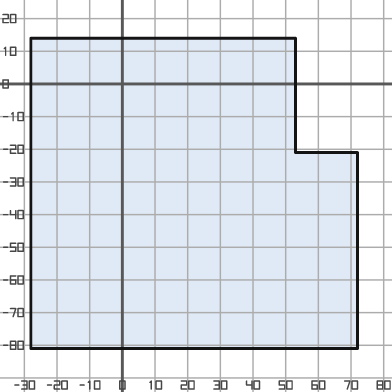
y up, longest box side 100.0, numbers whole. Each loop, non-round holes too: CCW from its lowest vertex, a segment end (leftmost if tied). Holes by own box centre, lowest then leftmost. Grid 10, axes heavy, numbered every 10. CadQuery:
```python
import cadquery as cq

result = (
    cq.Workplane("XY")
    .moveTo(-28.0, -81.0)
    .lineTo(72.0, -81.0)
    .lineTo(72.0, -21.0)
    .lineTo(53.0, -21.0)
    .lineTo(53.0, 14.0)
    .lineTo(-28.0, 14.0)
    .close()
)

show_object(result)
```